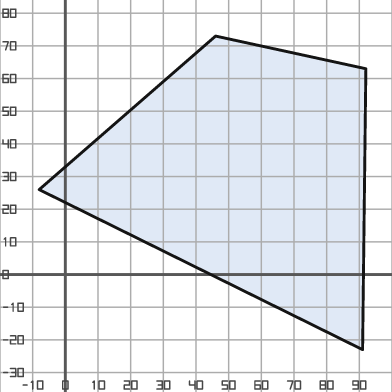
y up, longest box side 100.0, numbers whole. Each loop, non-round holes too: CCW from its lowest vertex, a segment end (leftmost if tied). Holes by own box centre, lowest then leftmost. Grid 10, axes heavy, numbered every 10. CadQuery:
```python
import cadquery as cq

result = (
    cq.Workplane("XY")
    .moveTo(91.0, -23.0)
    .lineTo(92.0, 63.0)
    .lineTo(46.0, 73.0)
    .lineTo(-8.0, 26.0)
    .close()
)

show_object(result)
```